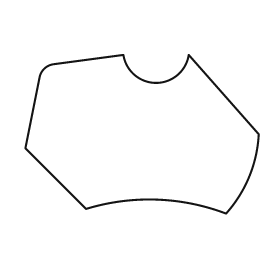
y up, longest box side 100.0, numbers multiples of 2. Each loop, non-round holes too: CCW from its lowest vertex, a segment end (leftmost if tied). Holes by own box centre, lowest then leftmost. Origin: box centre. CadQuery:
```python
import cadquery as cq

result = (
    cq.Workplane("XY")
    .moveTo(36.0, -34.0)
    .threePointArc((46.0, -18.0), (50.0, 0.0))
    .lineTo(20.0, 34.0)
    .threePointArc((6.0, 22.0), (-8.0, 34.0))
    .lineTo(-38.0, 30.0)
    .threePointArc((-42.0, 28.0), (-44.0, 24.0))
    .lineTo(-50.0, -6.0)
    .lineTo(-24.0, -32.0)
    .threePointArc((6.0, -28.0), (36.0, -34.0))
    .close()
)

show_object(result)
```